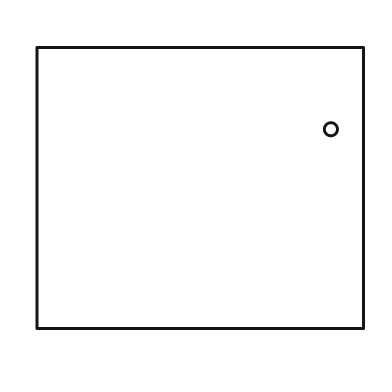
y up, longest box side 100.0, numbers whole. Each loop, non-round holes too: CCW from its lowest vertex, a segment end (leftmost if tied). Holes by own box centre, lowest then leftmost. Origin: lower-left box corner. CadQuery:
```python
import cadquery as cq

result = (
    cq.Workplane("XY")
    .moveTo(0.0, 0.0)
    .lineTo(100.0, 0.0)
    .lineTo(100.0, 86.0)
    .lineTo(0.0, 86.0)
    .close()
    .moveTo(90.0, 61.0)
    .circle(2.0)
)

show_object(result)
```